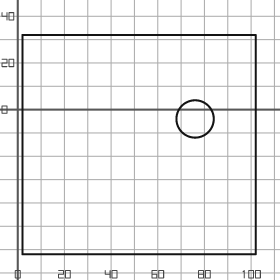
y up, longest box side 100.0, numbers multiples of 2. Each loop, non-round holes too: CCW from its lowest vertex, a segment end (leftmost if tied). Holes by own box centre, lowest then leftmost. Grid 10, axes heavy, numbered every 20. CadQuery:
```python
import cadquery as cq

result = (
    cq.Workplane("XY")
    .moveTo(2.0, -62.0)
    .lineTo(102.0, -62.0)
    .lineTo(102.0, 32.0)
    .lineTo(2.0, 32.0)
    .close()
    .moveTo(76.0, -4.0)
    .circle(8.0)
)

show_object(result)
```